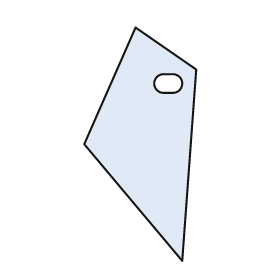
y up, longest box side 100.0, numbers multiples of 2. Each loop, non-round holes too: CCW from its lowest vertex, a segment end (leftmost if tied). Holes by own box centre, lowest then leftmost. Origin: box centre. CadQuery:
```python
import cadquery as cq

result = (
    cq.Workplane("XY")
    .moveTo(18.0, -50.0)
    .lineTo(24.0, 32.0)
    .lineTo(-2.0, 50.0)
    .lineTo(-24.0, 0.0)
    .close()
    .moveTo(10.0, 22.0)
    .lineTo(14.0, 22.0)
    .threePointArc((18.0, 26.0), (14.0, 30.0))
    .lineTo(10.0, 30.0)
    .threePointArc((6.0, 26.0), (10.0, 22.0))
    .close()
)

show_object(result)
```